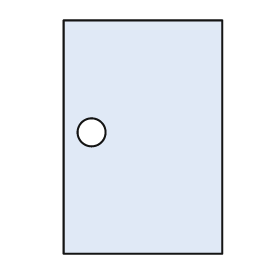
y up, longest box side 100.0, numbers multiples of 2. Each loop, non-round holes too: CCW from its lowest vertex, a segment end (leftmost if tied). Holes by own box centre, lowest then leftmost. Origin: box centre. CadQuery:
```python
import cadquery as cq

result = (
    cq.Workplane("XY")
    .moveTo(-34.0, -50.0)
    .lineTo(34.0, -50.0)
    .lineTo(34.0, 50.0)
    .lineTo(-34.0, 50.0)
    .close()
    .moveTo(-22.0, 2.0)
    .circle(6.0)
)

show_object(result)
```